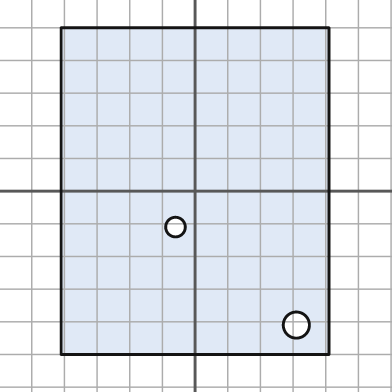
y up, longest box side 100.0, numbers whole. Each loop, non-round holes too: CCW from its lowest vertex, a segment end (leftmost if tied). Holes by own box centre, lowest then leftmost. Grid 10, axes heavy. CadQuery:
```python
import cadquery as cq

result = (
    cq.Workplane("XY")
    .moveTo(-41.0, -50.0)
    .lineTo(41.0, -50.0)
    .lineTo(41.0, 50.0)
    .lineTo(-41.0, 50.0)
    .close()
    .moveTo(31.0, -41.0)
    .circle(4.0)
    .moveTo(-6.0, -11.0)
    .circle(3.0)
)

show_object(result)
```